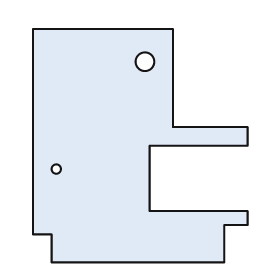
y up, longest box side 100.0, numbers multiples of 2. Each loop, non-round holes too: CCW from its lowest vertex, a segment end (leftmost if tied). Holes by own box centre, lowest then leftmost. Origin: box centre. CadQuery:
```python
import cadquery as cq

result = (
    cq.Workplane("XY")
    .moveTo(-38.0, -50.0)
    .lineTo(36.0, -50.0)
    .lineTo(36.0, -34.0)
    .lineTo(46.0, -34.0)
    .lineTo(46.0, -28.0)
    .lineTo(4.0, -28.0)
    .lineTo(4.0, 0.0)
    .lineTo(46.0, 0.0)
    .lineTo(46.0, 8.0)
    .lineTo(14.0, 8.0)
    .lineTo(14.0, 50.0)
    .lineTo(-46.0, 50.0)
    .lineTo(-46.0, -38.0)
    .lineTo(-38.0, -38.0)
    .close()
    .moveTo(-36.0, -10.0)
    .circle(2.0)
    .moveTo(2.0, 36.0)
    .circle(4.0)
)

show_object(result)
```